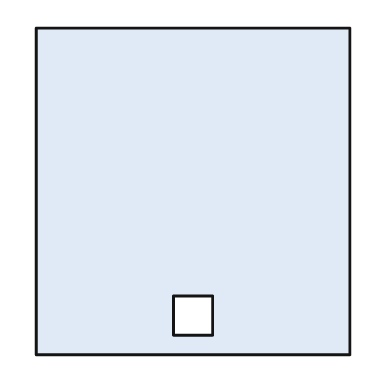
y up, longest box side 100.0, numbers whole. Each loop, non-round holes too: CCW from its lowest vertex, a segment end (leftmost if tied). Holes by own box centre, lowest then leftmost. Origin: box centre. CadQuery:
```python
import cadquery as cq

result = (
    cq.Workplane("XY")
    .moveTo(-48.0, -50.0)
    .lineTo(48.0, -50.0)
    .lineTo(48.0, 50.0)
    .lineTo(-48.0, 50.0)
    .close()
    .moveTo(-6.0, -44.0)
    .lineTo(6.0, -44.0)
    .lineTo(6.0, -32.0)
    .lineTo(-6.0, -32.0)
    .close()
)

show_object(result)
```